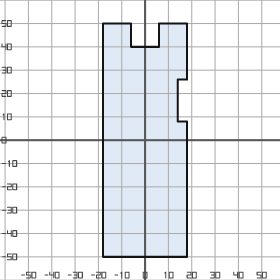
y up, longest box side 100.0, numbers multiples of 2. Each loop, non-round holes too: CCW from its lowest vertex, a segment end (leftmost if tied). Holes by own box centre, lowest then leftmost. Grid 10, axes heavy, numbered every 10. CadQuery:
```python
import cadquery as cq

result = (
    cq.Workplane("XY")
    .moveTo(-18.0, -50.0)
    .lineTo(18.0, -50.0)
    .lineTo(18.0, 8.0)
    .lineTo(14.0, 8.0)
    .lineTo(14.0, 26.0)
    .lineTo(18.0, 26.0)
    .lineTo(18.0, 50.0)
    .lineTo(6.0, 50.0)
    .lineTo(6.0, 40.0)
    .lineTo(-6.0, 40.0)
    .lineTo(-6.0, 50.0)
    .lineTo(-18.0, 50.0)
    .close()
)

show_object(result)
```